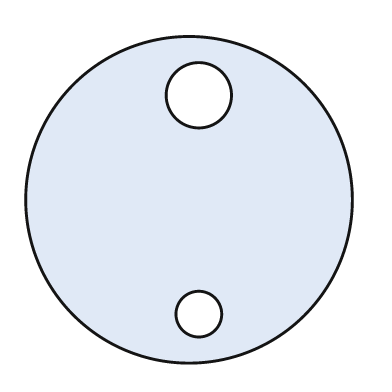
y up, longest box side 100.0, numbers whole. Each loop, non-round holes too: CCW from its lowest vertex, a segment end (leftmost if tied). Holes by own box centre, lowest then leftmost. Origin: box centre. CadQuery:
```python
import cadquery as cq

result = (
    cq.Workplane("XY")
    .moveTo(0.0, 0.0)
    .circle(50.0)
    .moveTo(3.0, -35.0)
    .circle(7.0)
    .moveTo(3.0, 32.0)
    .circle(10.0)
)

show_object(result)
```